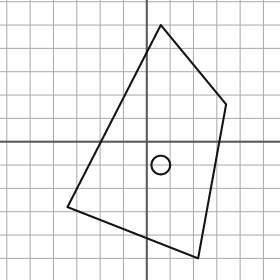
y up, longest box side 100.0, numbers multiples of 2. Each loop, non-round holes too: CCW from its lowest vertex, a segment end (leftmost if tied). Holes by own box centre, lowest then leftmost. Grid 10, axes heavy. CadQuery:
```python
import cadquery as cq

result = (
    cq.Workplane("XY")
    .moveTo(22.0, -50.0)
    .lineTo(34.0, 16.0)
    .lineTo(6.0, 50.0)
    .lineTo(-34.0, -28.0)
    .close()
    .moveTo(6.0, -10.0)
    .circle(4.0)
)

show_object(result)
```